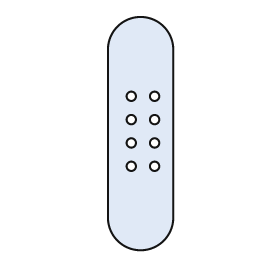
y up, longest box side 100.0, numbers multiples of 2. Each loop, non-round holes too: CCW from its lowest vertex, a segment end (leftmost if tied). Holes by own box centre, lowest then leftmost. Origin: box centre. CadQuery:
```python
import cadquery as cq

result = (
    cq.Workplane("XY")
    .moveTo(-14.0, -36.0)
    .threePointArc((0.0, -50.0), (14.0, -36.0))
    .lineTo(14.0, 36.0)
    .threePointArc((0.0, 50.0), (-14.0, 36.0))
    .close()
    .moveTo(-4.0, -14.0)
    .circle(2.0)
    .moveTo(6.0, -14.0)
    .circle(2.0)
    .moveTo(-4.0, -4.0)
    .circle(2.0)
    .moveTo(6.0, -4.0)
    .circle(2.0)
    .moveTo(-4.0, 6.0)
    .circle(2.0)
    .moveTo(6.0, 6.0)
    .circle(2.0)
    .moveTo(-4.0, 16.0)
    .circle(2.0)
    .moveTo(6.0, 16.0)
    .circle(2.0)
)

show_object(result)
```